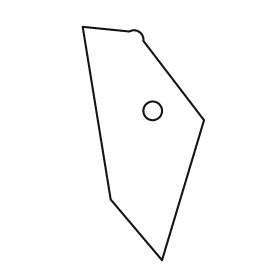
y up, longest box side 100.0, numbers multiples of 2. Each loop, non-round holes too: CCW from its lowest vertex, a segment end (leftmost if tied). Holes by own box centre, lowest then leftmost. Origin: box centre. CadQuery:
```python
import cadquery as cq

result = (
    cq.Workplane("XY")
    .moveTo(8.0, -50.0)
    .lineTo(26.0, 10.0)
    .lineTo(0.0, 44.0)
    .threePointArc((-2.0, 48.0), (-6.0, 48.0))
    .lineTo(-26.0, 50.0)
    .lineTo(-14.0, -24.0)
    .close()
    .moveTo(4.0, 14.0)
    .circle(4.0)
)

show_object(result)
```